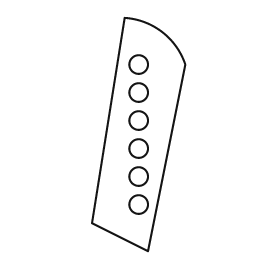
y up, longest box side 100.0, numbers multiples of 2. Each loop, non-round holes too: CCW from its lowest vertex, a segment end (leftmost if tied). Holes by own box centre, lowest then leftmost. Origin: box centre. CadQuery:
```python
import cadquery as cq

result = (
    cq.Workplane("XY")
    .moveTo(4.0, -50.0)
    .lineTo(20.0, 30.0)
    .threePointArc((10.0, 44.0), (-6.0, 50.0))
    .lineTo(-20.0, -38.0)
    .close()
    .moveTo(0.0, -30.0)
    .circle(4.0)
    .moveTo(0.0, -18.0)
    .circle(4.0)
    .moveTo(0.0, -6.0)
    .circle(4.0)
    .moveTo(0.0, 6.0)
    .circle(4.0)
    .moveTo(0.0, 18.0)
    .circle(4.0)
    .moveTo(0.0, 30.0)
    .circle(4.0)
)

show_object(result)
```